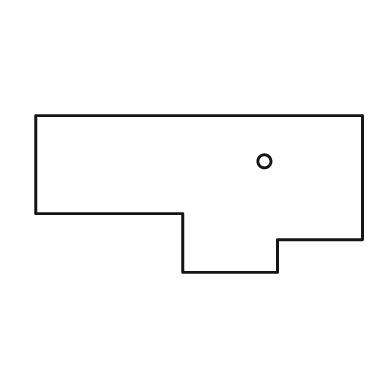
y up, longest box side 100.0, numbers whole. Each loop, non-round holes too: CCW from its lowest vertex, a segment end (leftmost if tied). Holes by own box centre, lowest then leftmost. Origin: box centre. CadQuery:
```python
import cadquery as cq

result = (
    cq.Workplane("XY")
    .moveTo(-5.0, -24.0)
    .lineTo(24.0, -24.0)
    .lineTo(24.0, -14.0)
    .lineTo(50.0, -14.0)
    .lineTo(50.0, 24.0)
    .lineTo(-50.0, 24.0)
    .lineTo(-50.0, -6.0)
    .lineTo(-5.0, -6.0)
    .close()
    .moveTo(20.0, 10.0)
    .circle(2.0)
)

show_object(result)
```